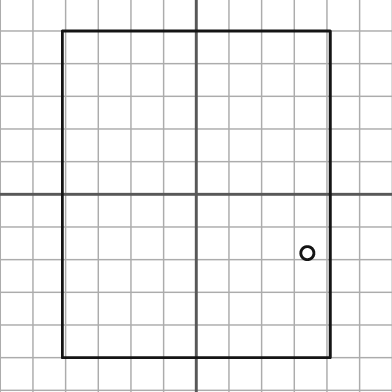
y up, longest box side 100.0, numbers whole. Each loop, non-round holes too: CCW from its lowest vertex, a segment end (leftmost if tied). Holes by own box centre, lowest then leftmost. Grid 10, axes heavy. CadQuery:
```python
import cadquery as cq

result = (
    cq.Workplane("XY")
    .moveTo(-41.0, -50.0)
    .lineTo(41.0, -50.0)
    .lineTo(41.0, 50.0)
    .lineTo(-41.0, 50.0)
    .close()
    .moveTo(34.0, -18.0)
    .circle(2.0)
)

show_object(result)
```